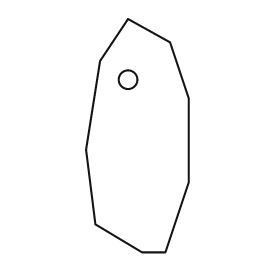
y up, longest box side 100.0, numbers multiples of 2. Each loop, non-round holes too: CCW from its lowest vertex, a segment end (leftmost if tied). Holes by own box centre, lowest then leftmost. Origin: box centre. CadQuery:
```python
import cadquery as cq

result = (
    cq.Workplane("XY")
    .moveTo(2.0, -50.0)
    .lineTo(12.0, -50.0)
    .lineTo(22.0, -20.0)
    .lineTo(22.0, 16.0)
    .lineTo(14.0, 40.0)
    .lineTo(-4.0, 50.0)
    .lineTo(-16.0, 32.0)
    .lineTo(-22.0, -6.0)
    .lineTo(-18.0, -38.0)
    .close()
    .moveTo(-4.0, 24.0)
    .circle(4.0)
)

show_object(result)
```